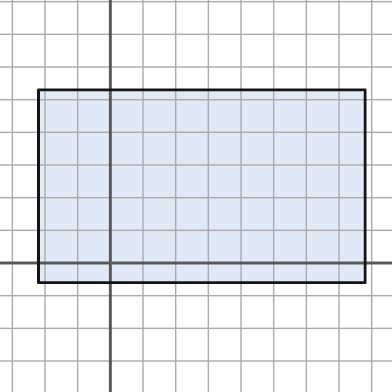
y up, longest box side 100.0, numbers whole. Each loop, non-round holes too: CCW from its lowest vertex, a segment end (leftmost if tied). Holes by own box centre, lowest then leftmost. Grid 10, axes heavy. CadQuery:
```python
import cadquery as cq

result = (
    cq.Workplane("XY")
    .moveTo(-22.0, -6.0)
    .lineTo(78.0, -6.0)
    .lineTo(78.0, 53.0)
    .lineTo(-22.0, 53.0)
    .close()
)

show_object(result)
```